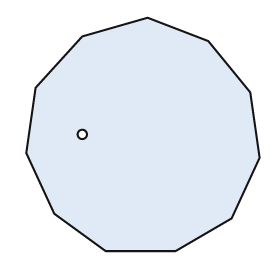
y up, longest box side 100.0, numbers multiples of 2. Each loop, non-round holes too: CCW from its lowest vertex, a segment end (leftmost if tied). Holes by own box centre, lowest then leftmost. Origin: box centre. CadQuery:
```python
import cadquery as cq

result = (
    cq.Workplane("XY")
    .moveTo(-16.0, -50.0)
    .lineTo(14.0, -50.0)
    .lineTo(38.0, -36.0)
    .lineTo(50.0, -10.0)
    .lineTo(46.0, 18.0)
    .lineTo(28.0, 40.0)
    .lineTo(2.0, 50.0)
    .lineTo(-26.0, 42.0)
    .lineTo(-46.0, 20.0)
    .lineTo(-50.0, -8.0)
    .lineTo(-38.0, -34.0)
    .close()
    .moveTo(-26.0, 0.0)
    .circle(2.0)
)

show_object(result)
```